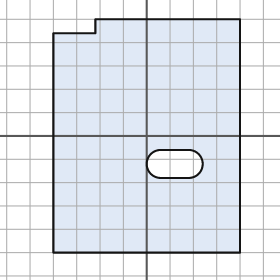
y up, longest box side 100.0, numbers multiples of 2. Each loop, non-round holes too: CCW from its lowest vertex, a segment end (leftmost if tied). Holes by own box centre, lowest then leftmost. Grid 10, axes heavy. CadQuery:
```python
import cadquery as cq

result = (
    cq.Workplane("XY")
    .moveTo(-40.0, -50.0)
    .lineTo(40.0, -50.0)
    .lineTo(40.0, 50.0)
    .lineTo(-22.0, 50.0)
    .lineTo(-22.0, 44.0)
    .lineTo(-40.0, 44.0)
    .close()
    .moveTo(6.0, -18.0)
    .lineTo(18.0, -18.0)
    .threePointArc((24.0, -12.0), (18.0, -6.0))
    .lineTo(6.0, -6.0)
    .threePointArc((0.0, -12.0), (6.0, -18.0))
    .close()
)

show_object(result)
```